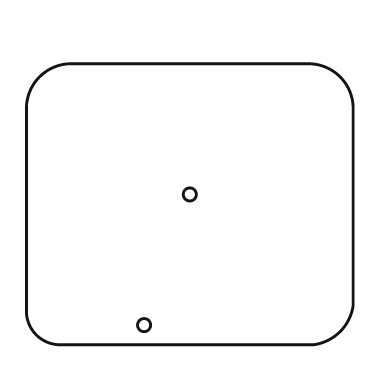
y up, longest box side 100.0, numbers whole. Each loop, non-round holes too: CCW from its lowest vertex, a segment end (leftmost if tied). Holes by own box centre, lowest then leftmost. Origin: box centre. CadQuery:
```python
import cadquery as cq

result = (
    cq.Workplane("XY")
    .moveTo(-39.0, -43.0)
    .lineTo(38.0, -43.0)
    .threePointArc((46.0, -39.0), (50.0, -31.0))
    .lineTo(50.0, 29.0)
    .threePointArc((46.0, 39.0), (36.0, 43.0))
    .lineTo(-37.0, 43.0)
    .threePointArc((-46.0, 39.0), (-50.0, 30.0))
    .lineTo(-50.0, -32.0)
    .threePointArc((-47.0, -40.0), (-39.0, -43.0))
    .close()
    .moveTo(-14.0, -37.0)
    .circle(2.0)
    .moveTo(0.0, 3.0)
    .circle(2.0)
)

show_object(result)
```